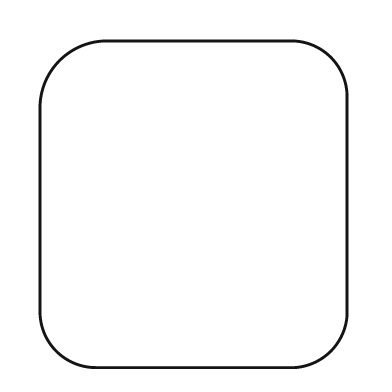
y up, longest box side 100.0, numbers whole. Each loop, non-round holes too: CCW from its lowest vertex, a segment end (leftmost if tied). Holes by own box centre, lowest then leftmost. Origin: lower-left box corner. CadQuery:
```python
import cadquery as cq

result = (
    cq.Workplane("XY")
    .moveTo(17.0, 0.0)
    .lineTo(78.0, 0.0)
    .threePointArc((89.0, 5.0), (94.0, 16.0))
    .lineTo(94.0, 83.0)
    .threePointArc((89.0, 95.0), (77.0, 100.0))
    .lineTo(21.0, 100.0)
    .threePointArc((6.0, 94.0), (0.0, 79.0))
    .lineTo(0.0, 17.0)
    .threePointArc((5.0, 5.0), (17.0, 0.0))
    .close()
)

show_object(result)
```